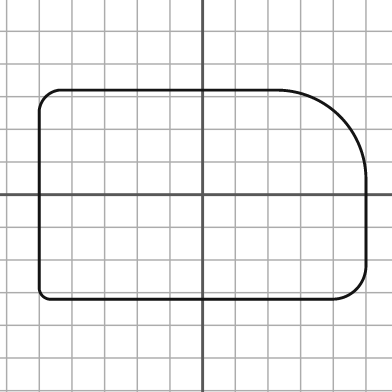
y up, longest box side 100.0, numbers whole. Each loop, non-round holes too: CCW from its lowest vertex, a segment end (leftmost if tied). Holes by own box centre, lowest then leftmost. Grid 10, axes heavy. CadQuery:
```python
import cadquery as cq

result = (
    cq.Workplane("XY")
    .moveTo(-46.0, -32.0)
    .lineTo(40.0, -32.0)
    .threePointArc((47.0, -29.0), (50.0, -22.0))
    .lineTo(50.0, 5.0)
    .threePointArc((42.0, 24.0), (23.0, 32.0))
    .lineTo(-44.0, 32.0)
    .threePointArc((-48.0, 30.0), (-50.0, 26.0))
    .lineTo(-50.0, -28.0)
    .threePointArc((-49.0, -31.0), (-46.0, -32.0))
    .close()
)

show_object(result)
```